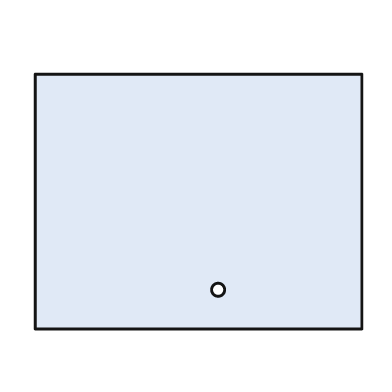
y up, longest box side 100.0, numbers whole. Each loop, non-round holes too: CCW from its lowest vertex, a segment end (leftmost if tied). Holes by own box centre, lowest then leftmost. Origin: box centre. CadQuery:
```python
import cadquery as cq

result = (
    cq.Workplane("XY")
    .moveTo(-50.0, -39.0)
    .lineTo(50.0, -39.0)
    .lineTo(50.0, 39.0)
    .lineTo(-50.0, 39.0)
    .close()
    .moveTo(6.0, -27.0)
    .circle(2.0)
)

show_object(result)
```